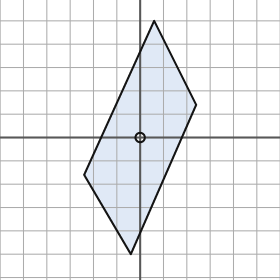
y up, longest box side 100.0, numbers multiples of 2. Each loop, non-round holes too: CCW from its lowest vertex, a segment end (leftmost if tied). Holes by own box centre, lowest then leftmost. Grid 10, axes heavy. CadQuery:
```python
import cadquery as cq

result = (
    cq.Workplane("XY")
    .moveTo(-4.0, -50.0)
    .lineTo(24.0, 14.0)
    .lineTo(6.0, 50.0)
    .lineTo(-24.0, -16.0)
    .close()
    .moveTo(0.0, 0.0)
    .circle(2.0)
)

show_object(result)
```